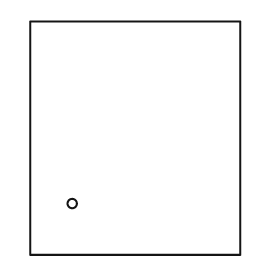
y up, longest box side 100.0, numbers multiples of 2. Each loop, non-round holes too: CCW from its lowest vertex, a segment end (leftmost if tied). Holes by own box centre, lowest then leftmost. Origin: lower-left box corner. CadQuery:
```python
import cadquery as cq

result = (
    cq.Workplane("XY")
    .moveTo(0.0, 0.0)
    .lineTo(90.0, 0.0)
    .lineTo(90.0, 100.0)
    .lineTo(0.0, 100.0)
    .close()
    .moveTo(18.0, 22.0)
    .circle(2.0)
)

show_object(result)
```